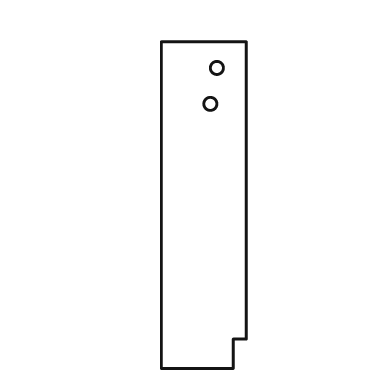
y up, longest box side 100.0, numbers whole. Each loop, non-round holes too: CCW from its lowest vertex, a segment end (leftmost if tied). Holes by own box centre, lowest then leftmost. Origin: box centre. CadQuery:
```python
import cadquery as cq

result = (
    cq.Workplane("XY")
    .moveTo(-13.0, -50.0)
    .lineTo(9.0, -50.0)
    .lineTo(9.0, -41.0)
    .lineTo(13.0, -41.0)
    .lineTo(13.0, 50.0)
    .lineTo(-13.0, 50.0)
    .close()
    .moveTo(2.0, 31.0)
    .circle(2.0)
    .moveTo(4.0, 42.0)
    .circle(2.0)
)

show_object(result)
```